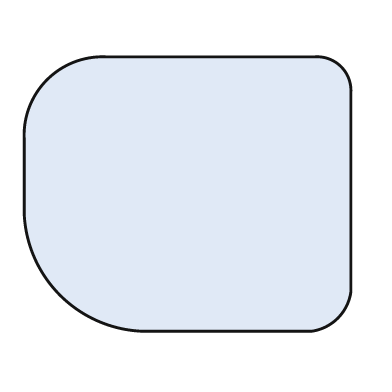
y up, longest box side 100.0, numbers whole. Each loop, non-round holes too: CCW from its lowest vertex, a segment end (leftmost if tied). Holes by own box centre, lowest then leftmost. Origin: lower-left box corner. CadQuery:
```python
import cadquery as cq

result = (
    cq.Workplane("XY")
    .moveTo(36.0, 0.0)
    .lineTo(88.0, 0.0)
    .threePointArc((96.0, 4.0), (100.0, 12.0))
    .lineTo(100.0, 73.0)
    .threePointArc((97.0, 81.0), (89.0, 84.0))
    .lineTo(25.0, 84.0)
    .threePointArc((7.0, 77.0), (0.0, 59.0))
    .lineTo(0.0, 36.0)
    .threePointArc((11.0, 11.0), (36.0, 0.0))
    .close()
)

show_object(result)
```